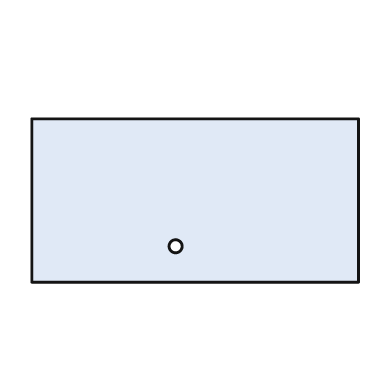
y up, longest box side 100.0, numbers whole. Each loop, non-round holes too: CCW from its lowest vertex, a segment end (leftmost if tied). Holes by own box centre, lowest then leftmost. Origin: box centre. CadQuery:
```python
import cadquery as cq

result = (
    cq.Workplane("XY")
    .moveTo(-50.0, -25.0)
    .lineTo(50.0, -25.0)
    .lineTo(50.0, 25.0)
    .lineTo(-50.0, 25.0)
    .close()
    .moveTo(-6.0, -14.0)
    .circle(2.0)
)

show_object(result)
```